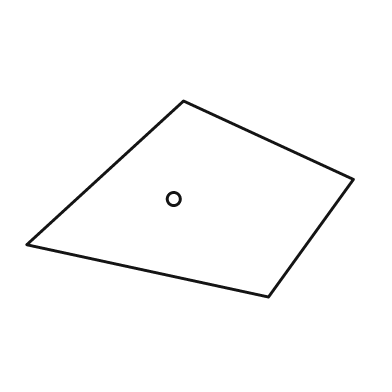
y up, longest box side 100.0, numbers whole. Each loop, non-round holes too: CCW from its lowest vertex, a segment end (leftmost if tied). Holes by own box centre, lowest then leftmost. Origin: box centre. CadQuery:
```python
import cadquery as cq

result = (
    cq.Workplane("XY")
    .moveTo(24.0, -30.0)
    .lineTo(50.0, 6.0)
    .lineTo(-2.0, 30.0)
    .lineTo(-50.0, -14.0)
    .close()
    .moveTo(-5.0, 0.0)
    .circle(2.0)
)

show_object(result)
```